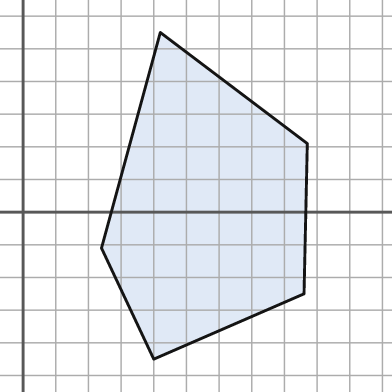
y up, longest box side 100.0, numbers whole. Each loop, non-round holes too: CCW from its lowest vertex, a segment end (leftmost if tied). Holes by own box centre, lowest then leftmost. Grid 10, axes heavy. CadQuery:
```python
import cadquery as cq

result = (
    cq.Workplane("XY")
    .moveTo(40.0, -45.0)
    .lineTo(86.0, -25.0)
    .lineTo(87.0, 21.0)
    .lineTo(42.0, 55.0)
    .lineTo(24.0, -11.0)
    .close()
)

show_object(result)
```